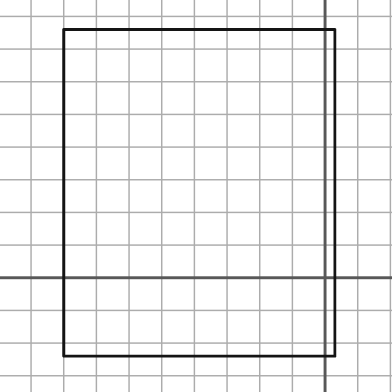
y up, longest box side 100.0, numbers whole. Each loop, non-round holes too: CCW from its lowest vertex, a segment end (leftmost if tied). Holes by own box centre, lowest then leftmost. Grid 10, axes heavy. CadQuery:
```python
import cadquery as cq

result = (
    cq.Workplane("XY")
    .moveTo(-80.0, -24.0)
    .lineTo(3.0, -24.0)
    .lineTo(3.0, 76.0)
    .lineTo(-80.0, 76.0)
    .close()
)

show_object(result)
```